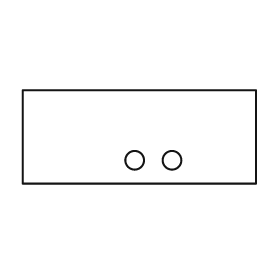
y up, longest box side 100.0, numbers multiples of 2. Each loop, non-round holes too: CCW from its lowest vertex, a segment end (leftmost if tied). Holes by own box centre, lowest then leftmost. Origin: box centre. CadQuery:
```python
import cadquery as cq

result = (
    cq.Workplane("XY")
    .moveTo(-50.0, -20.0)
    .lineTo(50.0, -20.0)
    .lineTo(50.0, 20.0)
    .lineTo(-50.0, 20.0)
    .close()
    .moveTo(-2.0, -10.0)
    .circle(4.0)
    .moveTo(14.0, -10.0)
    .circle(4.0)
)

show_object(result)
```